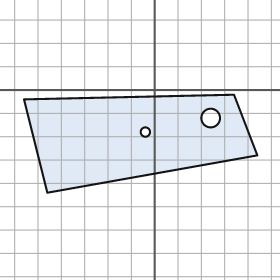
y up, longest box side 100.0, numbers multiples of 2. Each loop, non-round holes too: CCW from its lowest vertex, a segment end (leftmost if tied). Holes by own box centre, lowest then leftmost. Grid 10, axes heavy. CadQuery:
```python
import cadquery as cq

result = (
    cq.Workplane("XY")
    .moveTo(-46.0, -44.0)
    .lineTo(44.0, -28.0)
    .lineTo(34.0, -2.0)
    .lineTo(-56.0, -4.0)
    .close()
    .moveTo(-4.0, -18.0)
    .circle(2.0)
    .moveTo(24.0, -12.0)
    .circle(4.0)
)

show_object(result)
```